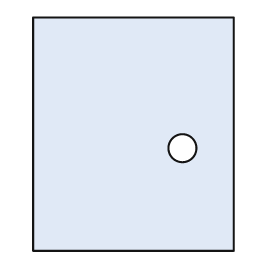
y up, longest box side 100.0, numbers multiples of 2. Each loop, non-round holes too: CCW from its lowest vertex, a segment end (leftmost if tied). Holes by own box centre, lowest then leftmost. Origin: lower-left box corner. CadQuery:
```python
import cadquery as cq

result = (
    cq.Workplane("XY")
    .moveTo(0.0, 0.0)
    .lineTo(86.0, 0.0)
    .lineTo(86.0, 100.0)
    .lineTo(0.0, 100.0)
    .close()
    .moveTo(64.0, 44.0)
    .circle(6.0)
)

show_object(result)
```